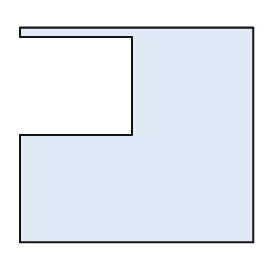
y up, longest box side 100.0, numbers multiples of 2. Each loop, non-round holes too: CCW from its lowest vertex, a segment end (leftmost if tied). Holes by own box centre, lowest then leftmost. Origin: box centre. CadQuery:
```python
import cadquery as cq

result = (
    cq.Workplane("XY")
    .moveTo(-50.0, -46.0)
    .lineTo(50.0, -46.0)
    .lineTo(50.0, 46.0)
    .lineTo(-50.0, 46.0)
    .lineTo(-50.0, 42.0)
    .lineTo(-2.0, 42.0)
    .lineTo(-2.0, 0.0)
    .lineTo(-50.0, 0.0)
    .close()
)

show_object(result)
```